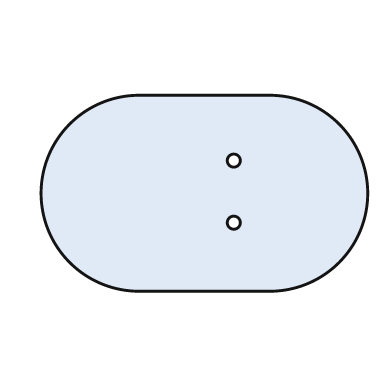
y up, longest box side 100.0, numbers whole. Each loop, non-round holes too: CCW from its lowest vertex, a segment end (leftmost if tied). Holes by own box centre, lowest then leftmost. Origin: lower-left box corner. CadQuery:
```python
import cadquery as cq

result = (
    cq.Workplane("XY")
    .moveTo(30.0, 0.0)
    .lineTo(70.0, 0.0)
    .threePointArc((100.0, 30.0), (70.0, 60.0))
    .lineTo(30.0, 60.0)
    .threePointArc((0.0, 30.0), (30.0, 0.0))
    .close()
    .moveTo(59.0, 21.0)
    .circle(2.0)
    .moveTo(59.0, 40.0)
    .circle(2.0)
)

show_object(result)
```